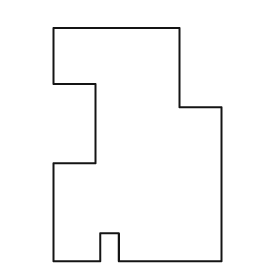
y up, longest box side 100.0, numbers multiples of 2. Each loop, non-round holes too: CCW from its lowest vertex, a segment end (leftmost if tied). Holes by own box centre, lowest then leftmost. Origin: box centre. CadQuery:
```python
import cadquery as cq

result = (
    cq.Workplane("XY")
    .moveTo(-36.0, -50.0)
    .lineTo(-16.0, -50.0)
    .lineTo(-16.0, -38.0)
    .lineTo(-8.0, -38.0)
    .lineTo(-8.0, -50.0)
    .lineTo(36.0, -50.0)
    .lineTo(36.0, 16.0)
    .lineTo(18.0, 16.0)
    .lineTo(18.0, 50.0)
    .lineTo(-36.0, 50.0)
    .lineTo(-36.0, 26.0)
    .lineTo(-18.0, 26.0)
    .lineTo(-18.0, -8.0)
    .lineTo(-36.0, -8.0)
    .close()
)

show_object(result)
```